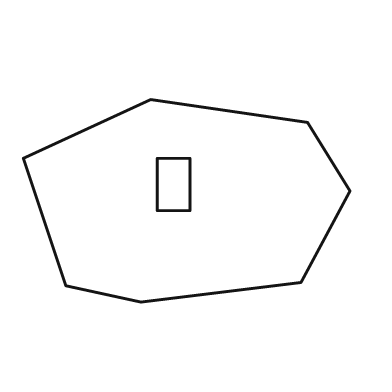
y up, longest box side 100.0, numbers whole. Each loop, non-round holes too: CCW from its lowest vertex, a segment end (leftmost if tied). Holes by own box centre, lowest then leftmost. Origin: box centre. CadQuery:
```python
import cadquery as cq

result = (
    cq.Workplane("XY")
    .moveTo(-14.0, -31.0)
    .lineTo(35.0, -25.0)
    .lineTo(50.0, 3.0)
    .lineTo(37.0, 24.0)
    .lineTo(-11.0, 31.0)
    .lineTo(-50.0, 13.0)
    .lineTo(-37.0, -26.0)
    .close()
    .moveTo(-9.0, -3.0)
    .lineTo(1.0, -3.0)
    .lineTo(1.0, 13.0)
    .lineTo(-9.0, 13.0)
    .close()
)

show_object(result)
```